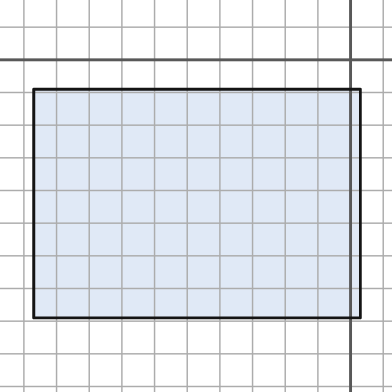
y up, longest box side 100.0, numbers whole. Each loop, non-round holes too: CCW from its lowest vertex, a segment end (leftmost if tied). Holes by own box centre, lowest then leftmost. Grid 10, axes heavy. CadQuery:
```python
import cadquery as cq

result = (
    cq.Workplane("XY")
    .moveTo(-97.0, -79.0)
    .lineTo(3.0, -79.0)
    .lineTo(3.0, -9.0)
    .lineTo(-97.0, -9.0)
    .close()
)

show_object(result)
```